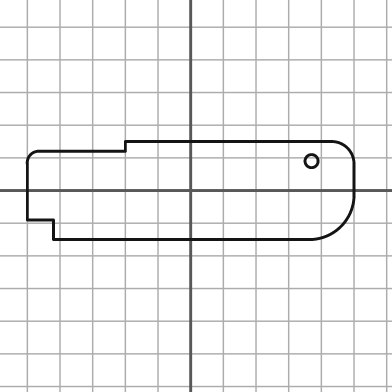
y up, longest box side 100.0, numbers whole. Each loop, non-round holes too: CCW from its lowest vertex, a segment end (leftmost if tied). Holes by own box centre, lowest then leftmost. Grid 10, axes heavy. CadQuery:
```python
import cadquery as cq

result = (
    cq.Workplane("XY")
    .moveTo(-42.0, -15.0)
    .lineTo(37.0, -15.0)
    .threePointArc((46.0, -11.0), (50.0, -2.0))
    .lineTo(50.0, 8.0)
    .threePointArc((48.0, 13.0), (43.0, 15.0))
    .lineTo(-20.0, 15.0)
    .lineTo(-20.0, 12.0)
    .lineTo(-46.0, 12.0)
    .threePointArc((-49.0, 11.0), (-50.0, 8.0))
    .lineTo(-50.0, -9.0)
    .lineTo(-42.0, -9.0)
    .close()
    .moveTo(37.0, 9.0)
    .circle(2.0)
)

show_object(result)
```